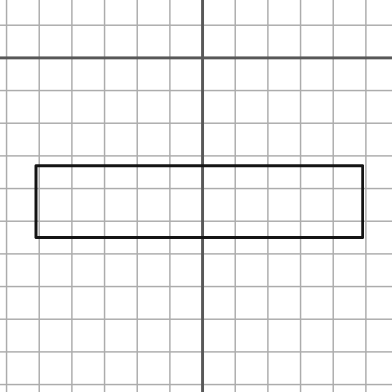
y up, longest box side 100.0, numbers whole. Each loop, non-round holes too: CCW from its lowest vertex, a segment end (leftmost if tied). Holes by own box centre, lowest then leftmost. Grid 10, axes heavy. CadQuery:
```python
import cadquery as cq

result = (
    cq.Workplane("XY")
    .moveTo(-51.0, -55.0)
    .lineTo(49.0, -55.0)
    .lineTo(49.0, -33.0)
    .lineTo(-51.0, -33.0)
    .close()
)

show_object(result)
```